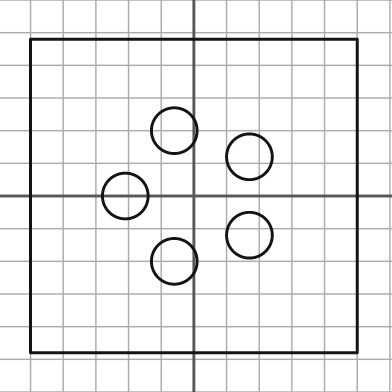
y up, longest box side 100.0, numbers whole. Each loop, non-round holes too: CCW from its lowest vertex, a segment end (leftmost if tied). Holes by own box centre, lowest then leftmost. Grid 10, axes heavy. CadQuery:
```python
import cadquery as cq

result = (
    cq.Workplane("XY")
    .moveTo(-50.0, -48.0)
    .lineTo(50.0, -48.0)
    .lineTo(50.0, 48.0)
    .lineTo(-50.0, 48.0)
    .close()
    .moveTo(-6.0, -20.0)
    .circle(7.0)
    .moveTo(17.0, -12.0)
    .circle(7.0)
    .moveTo(-21.0, 0.0)
    .circle(7.0)
    .moveTo(17.0, 12.0)
    .circle(7.0)
    .moveTo(-6.0, 20.0)
    .circle(7.0)
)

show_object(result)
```